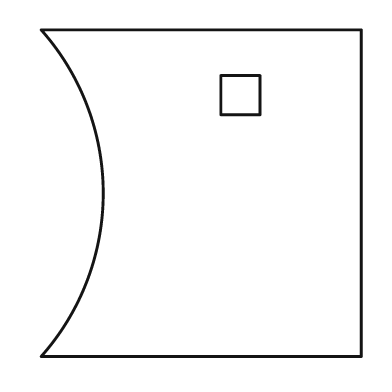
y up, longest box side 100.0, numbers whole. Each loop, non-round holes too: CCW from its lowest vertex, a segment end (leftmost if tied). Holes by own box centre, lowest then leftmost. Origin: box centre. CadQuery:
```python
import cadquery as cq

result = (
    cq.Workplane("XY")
    .moveTo(-49.0, -50.0)
    .lineTo(49.0, -50.0)
    .lineTo(49.0, 50.0)
    .lineTo(-49.0, 50.0)
    .threePointArc((-30.0, 0.0), (-49.0, -50.0))
    .close()
    .moveTo(6.0, 24.0)
    .lineTo(18.0, 24.0)
    .lineTo(18.0, 36.0)
    .lineTo(6.0, 36.0)
    .close()
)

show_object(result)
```